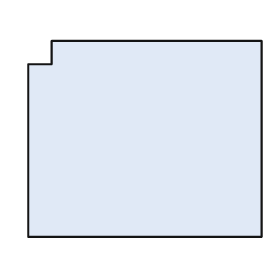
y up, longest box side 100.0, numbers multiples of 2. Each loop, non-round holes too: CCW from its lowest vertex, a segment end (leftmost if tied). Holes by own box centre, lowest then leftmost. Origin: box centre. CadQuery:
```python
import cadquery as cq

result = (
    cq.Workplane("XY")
    .moveTo(-50.0, -42.0)
    .lineTo(50.0, -42.0)
    .lineTo(50.0, 42.0)
    .lineTo(-40.0, 42.0)
    .lineTo(-40.0, 32.0)
    .lineTo(-50.0, 32.0)
    .close()
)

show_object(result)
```